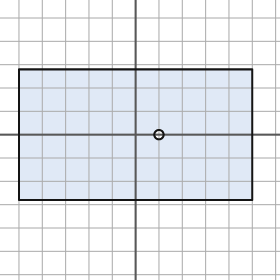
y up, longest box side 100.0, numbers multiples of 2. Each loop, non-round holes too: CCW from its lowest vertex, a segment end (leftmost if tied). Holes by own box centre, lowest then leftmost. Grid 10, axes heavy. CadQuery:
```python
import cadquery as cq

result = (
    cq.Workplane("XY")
    .moveTo(-50.0, -28.0)
    .lineTo(50.0, -28.0)
    .lineTo(50.0, 28.0)
    .lineTo(-50.0, 28.0)
    .close()
    .moveTo(10.0, 0.0)
    .circle(2.0)
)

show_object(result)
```